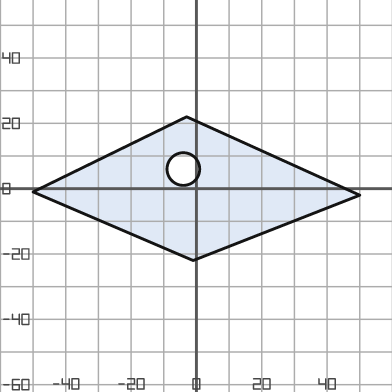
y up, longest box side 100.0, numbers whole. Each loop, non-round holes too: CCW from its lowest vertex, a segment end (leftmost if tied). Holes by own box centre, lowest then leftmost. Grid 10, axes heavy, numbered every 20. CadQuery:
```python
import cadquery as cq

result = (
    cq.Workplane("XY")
    .moveTo(-1.0, -22.0)
    .lineTo(50.0, -2.0)
    .lineTo(-3.0, 22.0)
    .lineTo(-50.0, -1.0)
    .close()
    .moveTo(-4.0, 6.0)
    .circle(5.0)
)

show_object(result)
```